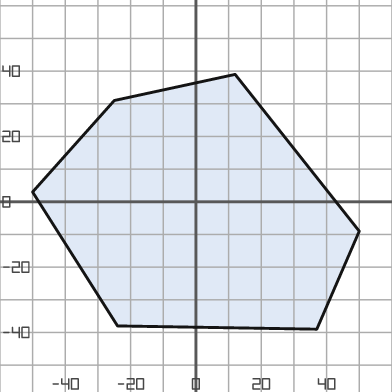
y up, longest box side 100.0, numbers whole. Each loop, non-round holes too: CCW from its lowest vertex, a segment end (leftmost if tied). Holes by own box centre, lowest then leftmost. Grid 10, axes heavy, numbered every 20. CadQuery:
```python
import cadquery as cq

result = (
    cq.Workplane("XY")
    .moveTo(37.0, -39.0)
    .lineTo(50.0, -9.0)
    .lineTo(12.0, 39.0)
    .lineTo(-25.0, 31.0)
    .lineTo(-50.0, 3.0)
    .lineTo(-24.0, -38.0)
    .close()
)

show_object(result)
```